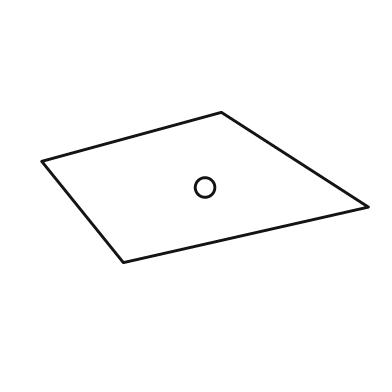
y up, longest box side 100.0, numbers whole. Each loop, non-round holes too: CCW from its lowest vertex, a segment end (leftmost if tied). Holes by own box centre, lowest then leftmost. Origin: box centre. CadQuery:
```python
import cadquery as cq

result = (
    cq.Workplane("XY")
    .moveTo(-25.0, -23.0)
    .lineTo(50.0, -6.0)
    .lineTo(5.0, 23.0)
    .lineTo(-50.0, 8.0)
    .close()
    .moveTo(0.0, 0.0)
    .circle(3.0)
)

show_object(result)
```